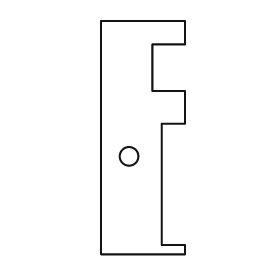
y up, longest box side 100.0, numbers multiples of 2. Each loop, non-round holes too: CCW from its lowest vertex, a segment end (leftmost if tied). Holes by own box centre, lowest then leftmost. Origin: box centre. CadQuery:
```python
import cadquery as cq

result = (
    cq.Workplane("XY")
    .moveTo(-18.0, -50.0)
    .lineTo(18.0, -50.0)
    .lineTo(18.0, -46.0)
    .lineTo(8.0, -46.0)
    .lineTo(8.0, 6.0)
    .lineTo(18.0, 6.0)
    .lineTo(18.0, 20.0)
    .lineTo(4.0, 20.0)
    .lineTo(4.0, 40.0)
    .lineTo(18.0, 40.0)
    .lineTo(18.0, 50.0)
    .lineTo(-18.0, 50.0)
    .close()
    .moveTo(-6.0, -8.0)
    .circle(4.0)
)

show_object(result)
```